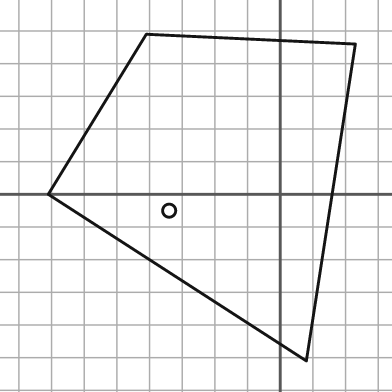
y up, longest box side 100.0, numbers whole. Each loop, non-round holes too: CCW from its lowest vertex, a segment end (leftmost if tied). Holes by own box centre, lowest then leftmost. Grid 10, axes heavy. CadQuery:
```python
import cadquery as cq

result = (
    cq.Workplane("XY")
    .moveTo(8.0, -51.0)
    .lineTo(23.0, 46.0)
    .lineTo(-41.0, 49.0)
    .lineTo(-71.0, 0.0)
    .close()
    .moveTo(-34.0, -5.0)
    .circle(2.0)
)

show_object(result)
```